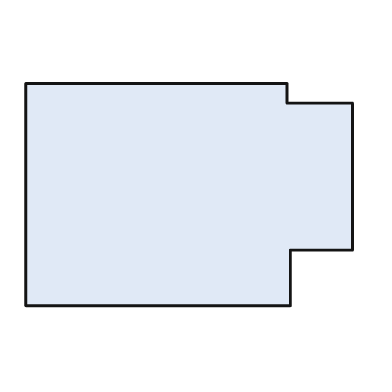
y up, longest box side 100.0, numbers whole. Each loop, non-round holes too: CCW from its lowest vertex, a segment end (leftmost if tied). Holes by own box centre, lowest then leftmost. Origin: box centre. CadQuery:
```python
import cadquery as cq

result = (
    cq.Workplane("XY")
    .moveTo(-50.0, -34.0)
    .lineTo(31.0, -34.0)
    .lineTo(31.0, -17.0)
    .lineTo(50.0, -17.0)
    .lineTo(50.0, 28.0)
    .lineTo(30.0, 28.0)
    .lineTo(30.0, 34.0)
    .lineTo(-50.0, 34.0)
    .close()
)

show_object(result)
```